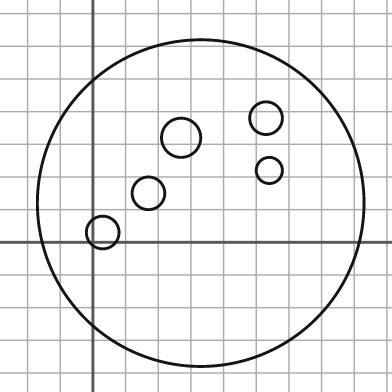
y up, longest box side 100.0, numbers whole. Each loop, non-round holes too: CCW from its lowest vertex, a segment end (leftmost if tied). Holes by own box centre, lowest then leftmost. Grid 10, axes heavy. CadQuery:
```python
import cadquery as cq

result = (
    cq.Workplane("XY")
    .moveTo(33.0, 12.0)
    .circle(50.0)
    .moveTo(3.0, 3.0)
    .circle(5.0)
    .moveTo(17.0, 15.0)
    .circle(5.0)
    .moveTo(54.0, 22.0)
    .circle(4.0)
    .moveTo(27.0, 32.0)
    .circle(6.0)
    .moveTo(53.0, 38.0)
    .circle(5.0)
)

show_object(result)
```